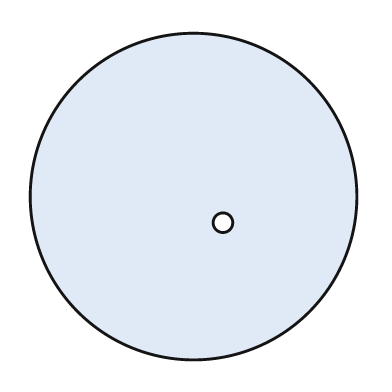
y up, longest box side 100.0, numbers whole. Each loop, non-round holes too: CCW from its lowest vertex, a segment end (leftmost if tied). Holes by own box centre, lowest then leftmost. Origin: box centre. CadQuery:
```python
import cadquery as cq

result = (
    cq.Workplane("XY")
    .moveTo(0.0, 0.0)
    .circle(50.0)
    .moveTo(9.0, -8.0)
    .circle(3.0)
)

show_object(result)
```